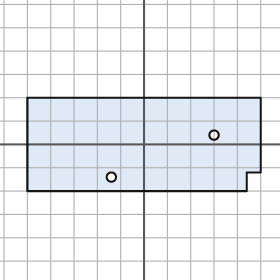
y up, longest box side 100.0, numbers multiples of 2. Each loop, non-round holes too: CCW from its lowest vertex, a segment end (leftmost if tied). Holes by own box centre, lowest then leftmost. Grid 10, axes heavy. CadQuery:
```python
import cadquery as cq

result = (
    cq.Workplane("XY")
    .moveTo(-50.0, -20.0)
    .lineTo(44.0, -20.0)
    .lineTo(44.0, -12.0)
    .lineTo(50.0, -12.0)
    .lineTo(50.0, 20.0)
    .lineTo(-50.0, 20.0)
    .close()
    .moveTo(-14.0, -14.0)
    .circle(2.0)
    .moveTo(30.0, 4.0)
    .circle(2.0)
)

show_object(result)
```